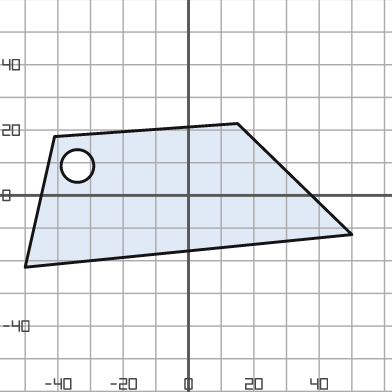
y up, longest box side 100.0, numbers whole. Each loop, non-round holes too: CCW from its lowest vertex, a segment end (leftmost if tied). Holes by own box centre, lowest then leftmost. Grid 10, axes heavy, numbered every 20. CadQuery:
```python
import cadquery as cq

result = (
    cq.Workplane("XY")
    .moveTo(-50.0, -22.0)
    .lineTo(50.0, -12.0)
    .lineTo(15.0, 22.0)
    .lineTo(-41.0, 18.0)
    .close()
    .moveTo(-34.0, 9.0)
    .circle(5.0)
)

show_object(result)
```